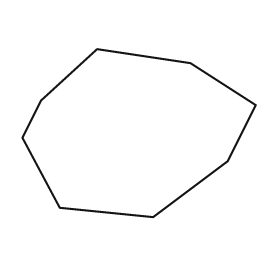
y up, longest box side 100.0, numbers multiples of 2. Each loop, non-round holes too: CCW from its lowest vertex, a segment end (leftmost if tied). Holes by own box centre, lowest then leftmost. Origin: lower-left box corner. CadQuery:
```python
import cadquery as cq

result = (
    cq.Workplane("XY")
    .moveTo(56.0, 0.0)
    .lineTo(88.0, 24.0)
    .lineTo(100.0, 48.0)
    .lineTo(72.0, 66.0)
    .lineTo(32.0, 72.0)
    .lineTo(8.0, 50.0)
    .lineTo(0.0, 34.0)
    .lineTo(16.0, 4.0)
    .close()
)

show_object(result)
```